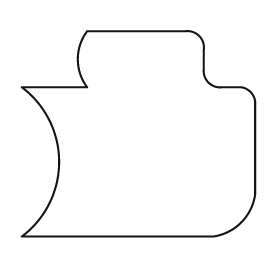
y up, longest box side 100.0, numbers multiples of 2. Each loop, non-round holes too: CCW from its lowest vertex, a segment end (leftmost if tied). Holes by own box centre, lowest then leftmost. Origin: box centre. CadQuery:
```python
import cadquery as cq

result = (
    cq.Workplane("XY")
    .moveTo(-50.0, -44.0)
    .lineTo(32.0, -44.0)
    .threePointArc((44.0, -38.0), (50.0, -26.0))
    .lineTo(50.0, 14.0)
    .threePointArc((48.0, 18.0), (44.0, 20.0))
    .lineTo(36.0, 20.0)
    .threePointArc((30.0, 22.0), (28.0, 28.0))
    .lineTo(28.0, 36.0)
    .threePointArc((26.0, 42.0), (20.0, 44.0))
    .lineTo(-22.0, 44.0)
    .threePointArc((-26.0, 32.0), (-22.0, 20.0))
    .lineTo(-50.0, 20.0)
    .threePointArc((-34.0, -12.0), (-50.0, -44.0))
    .close()
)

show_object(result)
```